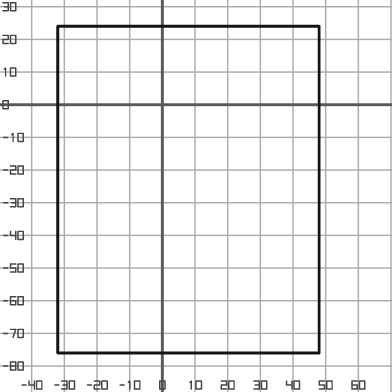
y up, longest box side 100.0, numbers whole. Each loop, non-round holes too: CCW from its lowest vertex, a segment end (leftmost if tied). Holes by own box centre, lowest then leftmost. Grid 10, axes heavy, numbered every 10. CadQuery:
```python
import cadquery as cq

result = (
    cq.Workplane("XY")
    .moveTo(-32.0, -76.0)
    .lineTo(48.0, -76.0)
    .lineTo(48.0, 24.0)
    .lineTo(-32.0, 24.0)
    .close()
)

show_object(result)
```